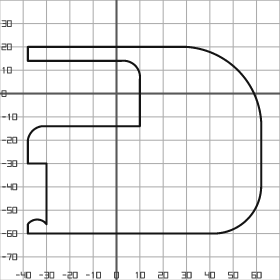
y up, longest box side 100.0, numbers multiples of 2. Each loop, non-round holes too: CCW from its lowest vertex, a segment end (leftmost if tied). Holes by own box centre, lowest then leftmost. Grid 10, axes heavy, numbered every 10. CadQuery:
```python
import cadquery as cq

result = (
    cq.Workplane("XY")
    .moveTo(-38.0, -60.0)
    .lineTo(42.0, -60.0)
    .threePointArc((56.0, -54.0), (62.0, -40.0))
    .lineTo(62.0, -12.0)
    .threePointArc((52.0, 10.0), (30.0, 20.0))
    .lineTo(-38.0, 20.0)
    .lineTo(-38.0, 14.0)
    .lineTo(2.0, 14.0)
    .threePointArc((8.0, 12.0), (10.0, 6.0))
    .lineTo(10.0, -14.0)
    .lineTo(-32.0, -14.0)
    .threePointArc((-36.0, -16.0), (-38.0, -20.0))
    .lineTo(-38.0, -30.0)
    .lineTo(-30.0, -30.0)
    .lineTo(-30.0, -56.0)
    .threePointArc((-34.0, -54.0), (-38.0, -56.0))
    .close()
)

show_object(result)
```